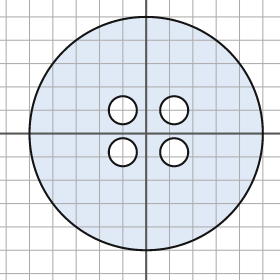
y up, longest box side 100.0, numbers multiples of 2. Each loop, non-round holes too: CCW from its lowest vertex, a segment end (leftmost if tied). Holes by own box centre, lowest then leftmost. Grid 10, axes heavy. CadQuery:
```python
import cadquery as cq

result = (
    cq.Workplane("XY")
    .moveTo(0.0, 0.0)
    .circle(50.0)
    .moveTo(-10.0, -8.0)
    .circle(6.0)
    .moveTo(12.0, -8.0)
    .circle(6.0)
    .moveTo(-10.0, 10.0)
    .circle(6.0)
    .moveTo(12.0, 10.0)
    .circle(6.0)
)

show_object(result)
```